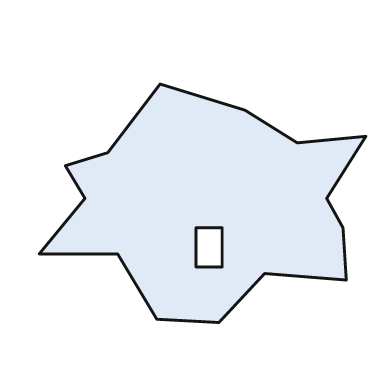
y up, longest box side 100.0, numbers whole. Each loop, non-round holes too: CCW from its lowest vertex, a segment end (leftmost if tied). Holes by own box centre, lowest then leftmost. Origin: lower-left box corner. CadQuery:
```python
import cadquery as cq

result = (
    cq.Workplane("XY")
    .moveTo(55.0, 0.0)
    .lineTo(69.0, 15.0)
    .lineTo(94.0, 13.0)
    .lineTo(93.0, 29.0)
    .lineTo(88.0, 38.0)
    .lineTo(100.0, 57.0)
    .lineTo(79.0, 55.0)
    .lineTo(63.0, 65.0)
    .lineTo(37.0, 73.0)
    .lineTo(21.0, 52.0)
    .lineTo(8.0, 48.0)
    .lineTo(14.0, 38.0)
    .lineTo(0.0, 21.0)
    .lineTo(24.0, 21.0)
    .lineTo(36.0, 1.0)
    .close()
    .moveTo(48.0, 17.0)
    .lineTo(56.0, 17.0)
    .lineTo(56.0, 29.0)
    .lineTo(48.0, 29.0)
    .close()
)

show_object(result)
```